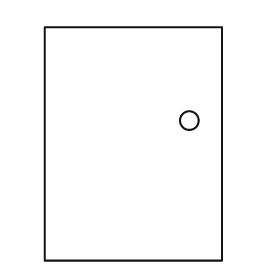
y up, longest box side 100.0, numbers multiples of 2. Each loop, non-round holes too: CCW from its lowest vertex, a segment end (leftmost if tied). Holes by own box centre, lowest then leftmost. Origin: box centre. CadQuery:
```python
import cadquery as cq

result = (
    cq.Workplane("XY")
    .moveTo(-38.0, -50.0)
    .lineTo(38.0, -50.0)
    .lineTo(38.0, 50.0)
    .lineTo(-38.0, 50.0)
    .close()
    .moveTo(24.0, 10.0)
    .circle(4.0)
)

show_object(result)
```